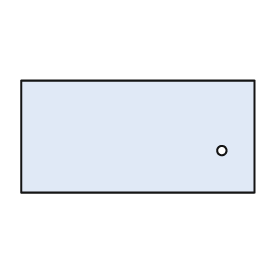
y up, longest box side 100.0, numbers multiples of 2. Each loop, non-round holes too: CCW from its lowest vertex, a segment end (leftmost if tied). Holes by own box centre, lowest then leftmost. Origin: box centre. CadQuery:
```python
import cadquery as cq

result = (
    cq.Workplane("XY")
    .moveTo(-50.0, -24.0)
    .lineTo(50.0, -24.0)
    .lineTo(50.0, 24.0)
    .lineTo(-50.0, 24.0)
    .close()
    .moveTo(36.0, -6.0)
    .circle(2.0)
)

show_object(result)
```